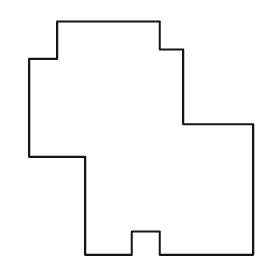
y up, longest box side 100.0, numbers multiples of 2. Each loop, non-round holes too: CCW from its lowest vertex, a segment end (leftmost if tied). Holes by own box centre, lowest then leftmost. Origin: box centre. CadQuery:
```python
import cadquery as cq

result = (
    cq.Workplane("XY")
    .moveTo(-24.0, -50.0)
    .lineTo(-4.0, -50.0)
    .lineTo(-4.0, -40.0)
    .lineTo(8.0, -40.0)
    .lineTo(8.0, -50.0)
    .lineTo(48.0, -50.0)
    .lineTo(48.0, 6.0)
    .lineTo(18.0, 6.0)
    .lineTo(18.0, 38.0)
    .lineTo(8.0, 38.0)
    .lineTo(8.0, 50.0)
    .lineTo(-36.0, 50.0)
    .lineTo(-36.0, 34.0)
    .lineTo(-48.0, 34.0)
    .lineTo(-48.0, -8.0)
    .lineTo(-24.0, -8.0)
    .close()
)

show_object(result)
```